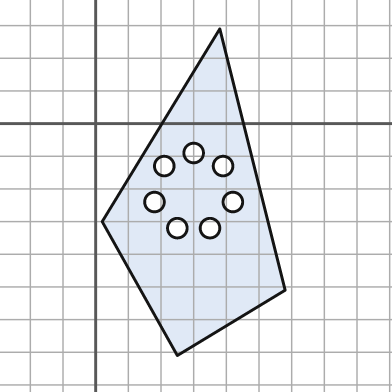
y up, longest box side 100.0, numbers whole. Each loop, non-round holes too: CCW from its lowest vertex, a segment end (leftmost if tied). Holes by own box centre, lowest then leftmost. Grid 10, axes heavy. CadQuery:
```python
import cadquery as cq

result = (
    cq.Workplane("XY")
    .moveTo(25.0, -71.0)
    .lineTo(58.0, -51.0)
    .lineTo(38.0, 29.0)
    .lineTo(2.0, -30.0)
    .close()
    .moveTo(25.0, -32.0)
    .circle(3.0)
    .moveTo(35.0, -32.0)
    .circle(3.0)
    .moveTo(18.0, -24.0)
    .circle(3.0)
    .moveTo(42.0, -24.0)
    .circle(3.0)
    .moveTo(21.0, -13.0)
    .circle(3.0)
    .moveTo(39.0, -13.0)
    .circle(3.0)
    .moveTo(30.0, -9.0)
    .circle(3.0)
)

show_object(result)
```